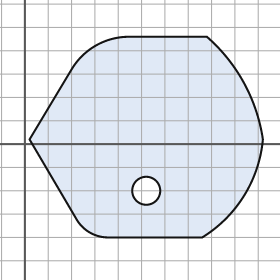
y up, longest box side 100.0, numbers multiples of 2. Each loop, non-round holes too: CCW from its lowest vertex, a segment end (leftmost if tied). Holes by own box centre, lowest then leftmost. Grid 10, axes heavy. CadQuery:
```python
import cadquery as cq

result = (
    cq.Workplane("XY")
    .moveTo(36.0, -40.0)
    .lineTo(76.0, -40.0)
    .threePointArc((94.0, -22.0), (102.0, 2.0))
    .threePointArc((94.0, 26.0), (78.0, 46.0))
    .lineTo(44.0, 46.0)
    .threePointArc((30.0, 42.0), (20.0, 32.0))
    .lineTo(2.0, 2.0)
    .lineTo(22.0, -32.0)
    .threePointArc((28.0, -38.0), (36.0, -40.0))
    .close()
    .moveTo(52.0, -20.0)
    .circle(6.0)
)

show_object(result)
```